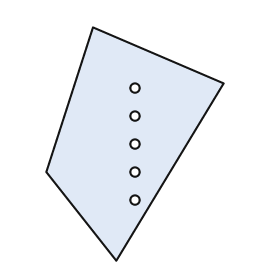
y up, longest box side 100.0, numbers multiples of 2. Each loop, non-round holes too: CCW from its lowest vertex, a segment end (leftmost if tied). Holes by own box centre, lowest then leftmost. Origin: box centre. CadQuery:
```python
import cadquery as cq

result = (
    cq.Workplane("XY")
    .moveTo(-8.0, -50.0)
    .lineTo(38.0, 26.0)
    .lineTo(-18.0, 50.0)
    .lineTo(-38.0, -12.0)
    .close()
    .moveTo(0.0, -24.0)
    .circle(2.0)
    .moveTo(0.0, -12.0)
    .circle(2.0)
    .moveTo(0.0, 0.0)
    .circle(2.0)
    .moveTo(0.0, 12.0)
    .circle(2.0)
    .moveTo(0.0, 24.0)
    .circle(2.0)
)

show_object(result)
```